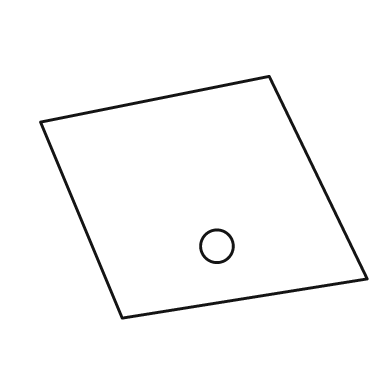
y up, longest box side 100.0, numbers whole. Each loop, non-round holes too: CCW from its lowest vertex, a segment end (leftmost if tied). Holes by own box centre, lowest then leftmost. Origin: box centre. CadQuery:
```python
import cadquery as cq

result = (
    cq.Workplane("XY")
    .moveTo(-25.0, -37.0)
    .lineTo(50.0, -25.0)
    .lineTo(20.0, 37.0)
    .lineTo(-50.0, 23.0)
    .close()
    .moveTo(4.0, -15.0)
    .circle(5.0)
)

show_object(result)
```